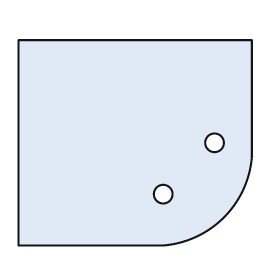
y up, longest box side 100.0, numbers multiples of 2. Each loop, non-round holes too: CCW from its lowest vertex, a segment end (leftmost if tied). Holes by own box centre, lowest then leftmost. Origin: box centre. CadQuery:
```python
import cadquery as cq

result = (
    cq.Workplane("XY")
    .moveTo(-50.0, -44.0)
    .lineTo(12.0, -44.0)
    .threePointArc((38.0, -32.0), (50.0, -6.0))
    .lineTo(50.0, 44.0)
    .lineTo(-50.0, 44.0)
    .close()
    .moveTo(12.0, -22.0)
    .circle(4.0)
    .moveTo(34.0, 0.0)
    .circle(4.0)
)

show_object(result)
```